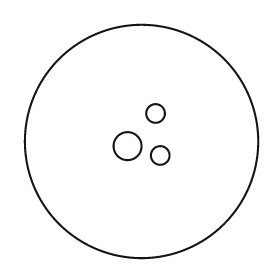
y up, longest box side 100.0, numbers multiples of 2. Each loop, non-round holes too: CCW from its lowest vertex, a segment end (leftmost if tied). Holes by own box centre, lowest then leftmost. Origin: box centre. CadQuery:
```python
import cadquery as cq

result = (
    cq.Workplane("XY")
    .moveTo(0.0, 0.0)
    .circle(50.0)
    .moveTo(8.0, -6.0)
    .circle(4.0)
    .moveTo(-6.0, -2.0)
    .circle(6.0)
    .moveTo(6.0, 12.0)
    .circle(4.0)
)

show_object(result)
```